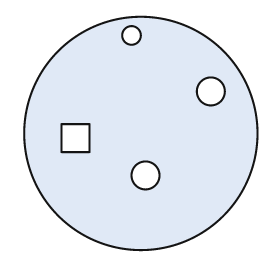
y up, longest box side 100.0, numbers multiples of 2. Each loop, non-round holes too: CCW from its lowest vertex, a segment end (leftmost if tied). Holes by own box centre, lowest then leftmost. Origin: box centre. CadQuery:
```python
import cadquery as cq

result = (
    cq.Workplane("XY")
    .moveTo(0.0, 0.0)
    .circle(50.0)
    .moveTo(2.0, -18.0)
    .circle(6.0)
    .moveTo(-34.0, -8.0)
    .lineTo(-22.0, -8.0)
    .lineTo(-22.0, 4.0)
    .lineTo(-34.0, 4.0)
    .close()
    .moveTo(30.0, 18.0)
    .circle(6.0)
    .moveTo(-4.0, 42.0)
    .circle(4.0)
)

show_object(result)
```